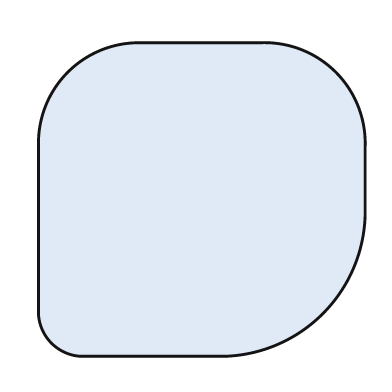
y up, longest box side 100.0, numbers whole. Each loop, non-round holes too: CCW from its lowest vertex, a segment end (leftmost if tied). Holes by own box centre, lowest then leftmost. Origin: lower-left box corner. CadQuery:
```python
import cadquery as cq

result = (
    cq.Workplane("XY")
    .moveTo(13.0, 0.0)
    .lineTo(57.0, 0.0)
    .threePointArc((87.0, 13.0), (100.0, 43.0))
    .lineTo(100.0, 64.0)
    .threePointArc((91.0, 87.0), (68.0, 96.0))
    .lineTo(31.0, 96.0)
    .threePointArc((9.0, 87.0), (0.0, 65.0))
    .lineTo(0.0, 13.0)
    .threePointArc((4.0, 4.0), (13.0, 0.0))
    .close()
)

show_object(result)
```